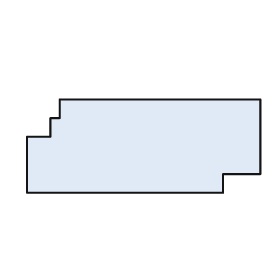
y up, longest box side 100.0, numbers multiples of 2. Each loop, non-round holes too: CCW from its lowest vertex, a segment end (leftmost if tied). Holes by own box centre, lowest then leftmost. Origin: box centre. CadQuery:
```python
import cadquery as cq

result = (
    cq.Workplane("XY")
    .moveTo(-50.0, -20.0)
    .lineTo(34.0, -20.0)
    .lineTo(34.0, -12.0)
    .lineTo(50.0, -12.0)
    .lineTo(50.0, 20.0)
    .lineTo(-36.0, 20.0)
    .lineTo(-36.0, 12.0)
    .lineTo(-40.0, 12.0)
    .lineTo(-40.0, 4.0)
    .lineTo(-50.0, 4.0)
    .close()
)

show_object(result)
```